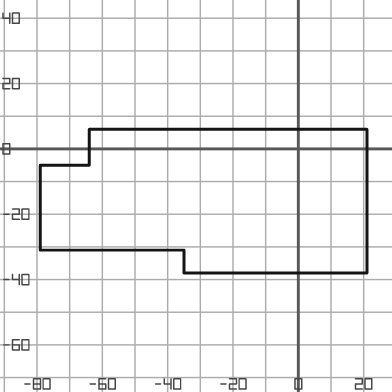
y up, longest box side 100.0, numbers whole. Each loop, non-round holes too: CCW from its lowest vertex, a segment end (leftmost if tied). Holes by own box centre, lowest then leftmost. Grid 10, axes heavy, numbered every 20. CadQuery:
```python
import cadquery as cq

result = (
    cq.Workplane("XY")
    .moveTo(-35.0, -38.0)
    .lineTo(21.0, -38.0)
    .lineTo(21.0, 6.0)
    .lineTo(-64.0, 6.0)
    .lineTo(-64.0, -5.0)
    .lineTo(-79.0, -5.0)
    .lineTo(-79.0, -31.0)
    .lineTo(-35.0, -31.0)
    .close()
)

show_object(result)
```